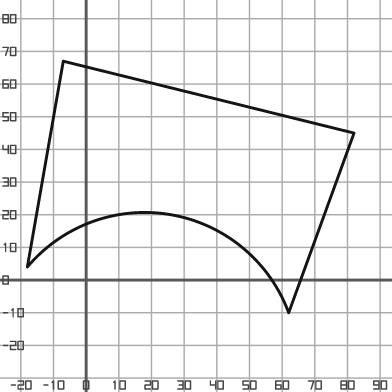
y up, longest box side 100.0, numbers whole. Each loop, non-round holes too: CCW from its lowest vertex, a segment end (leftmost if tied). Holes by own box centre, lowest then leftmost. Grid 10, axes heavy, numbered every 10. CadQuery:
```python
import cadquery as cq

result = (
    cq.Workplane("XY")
    .moveTo(62.0, -10.0)
    .lineTo(82.0, 45.0)
    .lineTo(-7.0, 67.0)
    .lineTo(-18.0, 4.0)
    .threePointArc((26.0, 20.0), (62.0, -10.0))
    .close()
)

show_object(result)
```